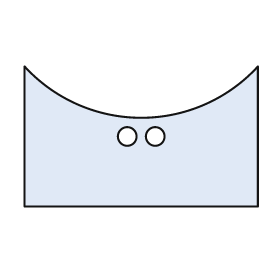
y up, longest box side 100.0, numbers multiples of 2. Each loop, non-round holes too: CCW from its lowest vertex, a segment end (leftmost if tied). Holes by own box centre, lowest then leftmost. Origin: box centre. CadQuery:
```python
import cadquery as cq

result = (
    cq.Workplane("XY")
    .moveTo(-50.0, -30.0)
    .lineTo(50.0, -30.0)
    .lineTo(50.0, 30.0)
    .threePointArc((0.0, 8.0), (-50.0, 30.0))
    .close()
    .moveTo(-6.0, 0.0)
    .circle(4.0)
    .moveTo(6.0, 0.0)
    .circle(4.0)
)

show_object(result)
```